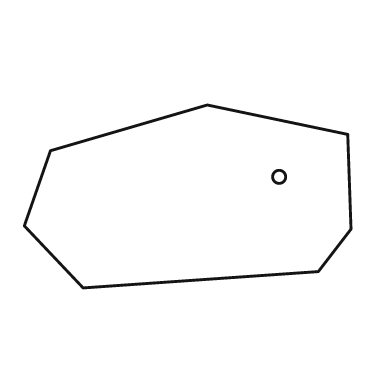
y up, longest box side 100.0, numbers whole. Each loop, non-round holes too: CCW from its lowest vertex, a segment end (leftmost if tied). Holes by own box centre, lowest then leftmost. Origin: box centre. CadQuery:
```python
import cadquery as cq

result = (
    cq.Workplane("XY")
    .moveTo(-32.0, -28.0)
    .lineTo(40.0, -23.0)
    .lineTo(50.0, -10.0)
    .lineTo(49.0, 19.0)
    .lineTo(6.0, 28.0)
    .lineTo(-42.0, 14.0)
    .lineTo(-50.0, -9.0)
    .close()
    .moveTo(28.0, 6.0)
    .circle(2.0)
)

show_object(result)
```